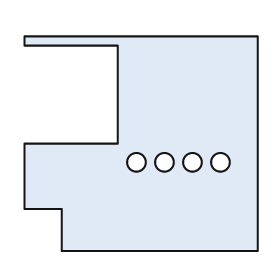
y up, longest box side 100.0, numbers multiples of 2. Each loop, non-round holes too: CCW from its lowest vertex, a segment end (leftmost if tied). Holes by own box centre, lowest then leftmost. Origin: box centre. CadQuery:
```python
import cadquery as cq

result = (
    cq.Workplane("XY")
    .moveTo(-34.0, -46.0)
    .lineTo(50.0, -46.0)
    .lineTo(50.0, 46.0)
    .lineTo(-50.0, 46.0)
    .lineTo(-50.0, 42.0)
    .lineTo(-10.0, 42.0)
    .lineTo(-10.0, 0.0)
    .lineTo(-50.0, 0.0)
    .lineTo(-50.0, -28.0)
    .lineTo(-34.0, -28.0)
    .close()
    .moveTo(-2.0, -8.0)
    .circle(4.0)
    .moveTo(10.0, -8.0)
    .circle(4.0)
    .moveTo(22.0, -8.0)
    .circle(4.0)
    .moveTo(34.0, -8.0)
    .circle(4.0)
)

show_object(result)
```